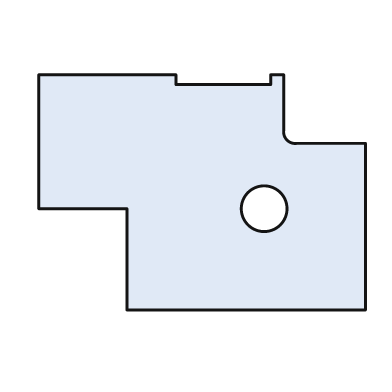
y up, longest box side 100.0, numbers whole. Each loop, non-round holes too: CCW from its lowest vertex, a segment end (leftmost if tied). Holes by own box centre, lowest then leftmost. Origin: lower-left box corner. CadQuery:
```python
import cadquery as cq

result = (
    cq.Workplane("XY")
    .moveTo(27.0, 0.0)
    .lineTo(100.0, 0.0)
    .lineTo(100.0, 51.0)
    .lineTo(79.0, 51.0)
    .threePointArc((76.0, 52.0), (75.0, 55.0))
    .lineTo(75.0, 72.0)
    .lineTo(71.0, 72.0)
    .lineTo(71.0, 69.0)
    .lineTo(42.0, 69.0)
    .lineTo(42.0, 72.0)
    .lineTo(0.0, 72.0)
    .lineTo(0.0, 31.0)
    .lineTo(27.0, 31.0)
    .close()
    .moveTo(69.0, 31.0)
    .circle(7.0)
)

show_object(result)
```